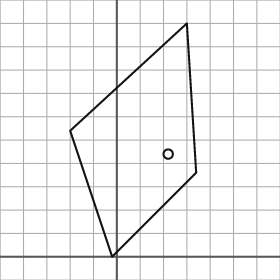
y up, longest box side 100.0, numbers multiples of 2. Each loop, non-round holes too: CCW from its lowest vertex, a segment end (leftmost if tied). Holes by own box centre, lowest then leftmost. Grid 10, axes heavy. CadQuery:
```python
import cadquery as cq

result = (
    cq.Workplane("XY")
    .moveTo(-2.0, 0.0)
    .lineTo(34.0, 36.0)
    .lineTo(30.0, 100.0)
    .lineTo(-20.0, 54.0)
    .close()
    .moveTo(22.0, 44.0)
    .circle(2.0)
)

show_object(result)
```